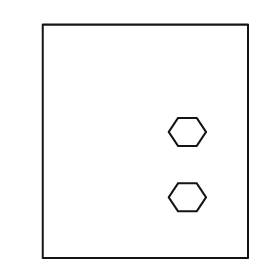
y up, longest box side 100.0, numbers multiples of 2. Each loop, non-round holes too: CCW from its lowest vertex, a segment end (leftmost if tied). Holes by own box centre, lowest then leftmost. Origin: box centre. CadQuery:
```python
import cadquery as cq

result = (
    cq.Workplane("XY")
    .moveTo(-44.0, -50.0)
    .lineTo(44.0, -50.0)
    .lineTo(44.0, 50.0)
    .lineTo(-44.0, 50.0)
    .close()
    .moveTo(14.0, -30.0)
    .lineTo(22.0, -30.0)
    .lineTo(26.0, -24.0)
    .lineTo(22.0, -18.0)
    .lineTo(14.0, -18.0)
    .lineTo(10.0, -24.0)
    .close()
    .moveTo(14.0, -2.0)
    .lineTo(22.0, -2.0)
    .lineTo(26.0, 4.0)
    .lineTo(22.0, 10.0)
    .lineTo(14.0, 10.0)
    .lineTo(10.0, 4.0)
    .close()
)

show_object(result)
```